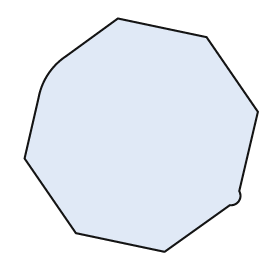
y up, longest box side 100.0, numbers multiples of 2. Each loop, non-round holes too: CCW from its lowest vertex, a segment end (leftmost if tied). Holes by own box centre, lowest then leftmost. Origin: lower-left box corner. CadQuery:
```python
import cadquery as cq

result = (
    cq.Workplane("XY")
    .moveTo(60.0, 0.0)
    .lineTo(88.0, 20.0)
    .threePointArc((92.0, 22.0), (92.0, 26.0))
    .lineTo(100.0, 60.0)
    .lineTo(78.0, 92.0)
    .lineTo(40.0, 100.0)
    .lineTo(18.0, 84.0)
    .threePointArc((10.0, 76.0), (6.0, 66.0))
    .lineTo(0.0, 40.0)
    .lineTo(22.0, 8.0)
    .close()
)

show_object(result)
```